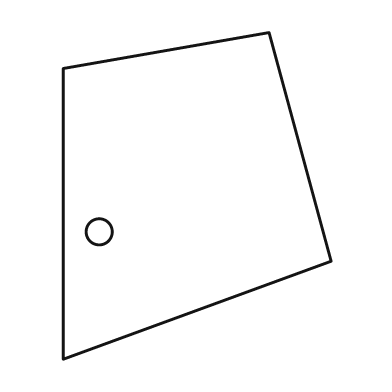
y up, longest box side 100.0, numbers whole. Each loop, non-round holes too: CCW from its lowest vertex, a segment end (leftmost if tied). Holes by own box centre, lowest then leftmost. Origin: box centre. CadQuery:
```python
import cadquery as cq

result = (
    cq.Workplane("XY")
    .moveTo(-41.0, -50.0)
    .lineTo(41.0, -20.0)
    .lineTo(22.0, 50.0)
    .lineTo(-41.0, 39.0)
    .close()
    .moveTo(-30.0, -11.0)
    .circle(4.0)
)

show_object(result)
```